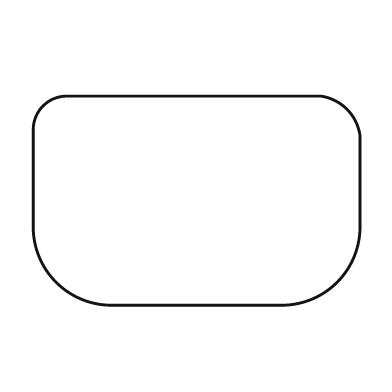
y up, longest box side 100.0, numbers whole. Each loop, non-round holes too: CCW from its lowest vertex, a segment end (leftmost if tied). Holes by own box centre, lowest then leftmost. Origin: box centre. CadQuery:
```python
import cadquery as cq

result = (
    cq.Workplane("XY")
    .moveTo(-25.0, -32.0)
    .lineTo(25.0, -32.0)
    .threePointArc((43.0, -25.0), (50.0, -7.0))
    .lineTo(50.0, 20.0)
    .threePointArc((46.0, 28.0), (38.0, 32.0))
    .lineTo(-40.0, 32.0)
    .threePointArc((-47.0, 29.0), (-50.0, 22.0))
    .lineTo(-50.0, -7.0)
    .threePointArc((-43.0, -25.0), (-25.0, -32.0))
    .close()
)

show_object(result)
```